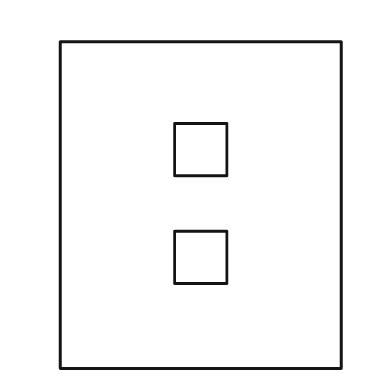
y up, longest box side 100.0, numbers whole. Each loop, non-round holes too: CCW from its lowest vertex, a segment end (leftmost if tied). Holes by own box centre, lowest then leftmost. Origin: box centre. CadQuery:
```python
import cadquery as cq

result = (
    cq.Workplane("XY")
    .moveTo(-43.0, -50.0)
    .lineTo(43.0, -50.0)
    .lineTo(43.0, 50.0)
    .lineTo(-43.0, 50.0)
    .close()
    .moveTo(-8.0, -24.0)
    .lineTo(8.0, -24.0)
    .lineTo(8.0, -8.0)
    .lineTo(-8.0, -8.0)
    .close()
    .moveTo(-8.0, 9.0)
    .lineTo(8.0, 9.0)
    .lineTo(8.0, 25.0)
    .lineTo(-8.0, 25.0)
    .close()
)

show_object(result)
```